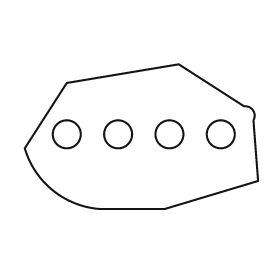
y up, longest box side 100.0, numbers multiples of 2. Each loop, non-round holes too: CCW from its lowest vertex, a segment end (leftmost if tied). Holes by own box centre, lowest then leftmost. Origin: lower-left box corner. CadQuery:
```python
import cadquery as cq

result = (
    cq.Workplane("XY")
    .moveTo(32.0, 0.0)
    .lineTo(60.0, 0.0)
    .lineTo(100.0, 12.0)
    .lineTo(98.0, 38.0)
    .threePointArc((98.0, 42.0), (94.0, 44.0))
    .lineTo(66.0, 62.0)
    .lineTo(18.0, 54.0)
    .lineTo(0.0, 26.0)
    .threePointArc((12.0, 8.0), (32.0, 0.0))
    .close()
    .moveTo(18.0, 32.0)
    .circle(6.0)
    .moveTo(40.0, 32.0)
    .circle(6.0)
    .moveTo(62.0, 32.0)
    .circle(6.0)
    .moveTo(84.0, 32.0)
    .circle(6.0)
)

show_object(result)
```